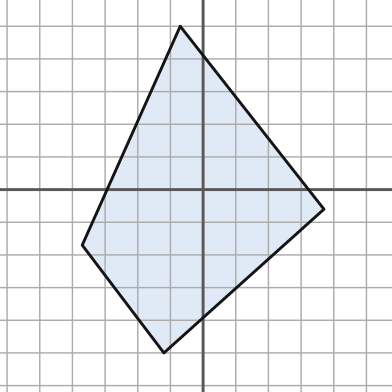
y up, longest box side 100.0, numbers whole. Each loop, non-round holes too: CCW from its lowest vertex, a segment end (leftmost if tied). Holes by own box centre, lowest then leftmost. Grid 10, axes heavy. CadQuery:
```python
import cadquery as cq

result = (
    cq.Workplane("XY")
    .moveTo(-12.0, -50.0)
    .lineTo(37.0, -6.0)
    .lineTo(-7.0, 50.0)
    .lineTo(-37.0, -17.0)
    .close()
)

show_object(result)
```